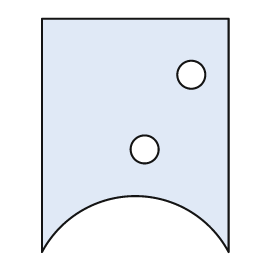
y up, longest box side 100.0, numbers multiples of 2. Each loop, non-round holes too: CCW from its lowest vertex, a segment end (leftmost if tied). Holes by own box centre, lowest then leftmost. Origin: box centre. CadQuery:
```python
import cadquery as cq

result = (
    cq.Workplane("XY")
    .moveTo(-40.0, -50.0)
    .threePointArc((0.0, -26.0), (40.0, -50.0))
    .lineTo(40.0, 50.0)
    .lineTo(-40.0, 50.0)
    .close()
    .moveTo(4.0, -6.0)
    .circle(6.0)
    .moveTo(24.0, 26.0)
    .circle(6.0)
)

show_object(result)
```